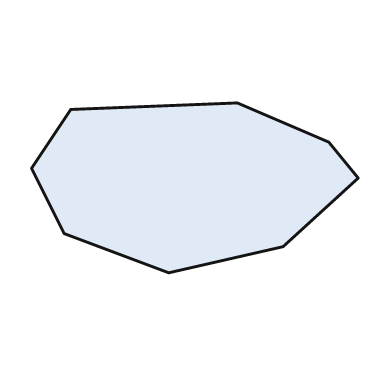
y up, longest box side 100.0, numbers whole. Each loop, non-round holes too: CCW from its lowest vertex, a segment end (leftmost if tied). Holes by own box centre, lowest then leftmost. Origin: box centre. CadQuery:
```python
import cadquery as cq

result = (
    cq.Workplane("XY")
    .moveTo(-8.0, -26.0)
    .lineTo(27.0, -18.0)
    .lineTo(50.0, 3.0)
    .lineTo(41.0, 14.0)
    .lineTo(13.0, 26.0)
    .lineTo(-38.0, 24.0)
    .lineTo(-50.0, 6.0)
    .lineTo(-40.0, -14.0)
    .close()
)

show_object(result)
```